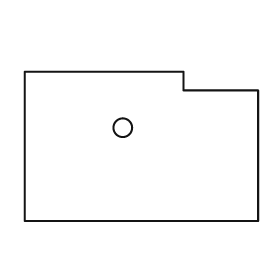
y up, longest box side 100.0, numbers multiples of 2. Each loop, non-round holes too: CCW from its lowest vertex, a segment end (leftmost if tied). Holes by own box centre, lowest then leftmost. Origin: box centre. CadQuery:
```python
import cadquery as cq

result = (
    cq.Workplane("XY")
    .moveTo(-50.0, -32.0)
    .lineTo(50.0, -32.0)
    .lineTo(50.0, 24.0)
    .lineTo(18.0, 24.0)
    .lineTo(18.0, 32.0)
    .lineTo(-50.0, 32.0)
    .close()
    .moveTo(-8.0, 8.0)
    .circle(4.0)
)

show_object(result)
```